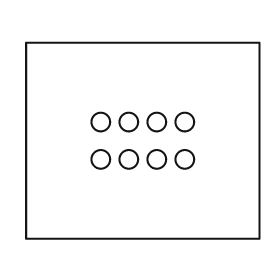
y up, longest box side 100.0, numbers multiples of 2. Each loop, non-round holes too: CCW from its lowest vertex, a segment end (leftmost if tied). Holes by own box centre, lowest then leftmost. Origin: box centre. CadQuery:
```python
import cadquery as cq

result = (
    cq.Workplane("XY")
    .moveTo(-50.0, -42.0)
    .lineTo(50.0, -42.0)
    .lineTo(50.0, 42.0)
    .lineTo(-50.0, 42.0)
    .close()
    .moveTo(-18.0, -8.0)
    .circle(4.0)
    .moveTo(-6.0, -8.0)
    .circle(4.0)
    .moveTo(6.0, -8.0)
    .circle(4.0)
    .moveTo(18.0, -8.0)
    .circle(4.0)
    .moveTo(-18.0, 8.0)
    .circle(4.0)
    .moveTo(-6.0, 8.0)
    .circle(4.0)
    .moveTo(6.0, 8.0)
    .circle(4.0)
    .moveTo(18.0, 8.0)
    .circle(4.0)
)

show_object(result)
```